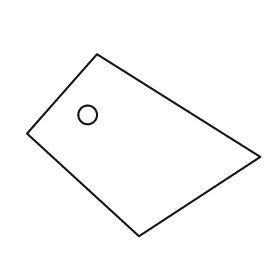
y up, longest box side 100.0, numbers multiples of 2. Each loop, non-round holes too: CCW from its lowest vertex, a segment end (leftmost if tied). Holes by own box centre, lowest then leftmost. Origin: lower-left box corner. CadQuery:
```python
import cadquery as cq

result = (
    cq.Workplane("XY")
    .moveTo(48.0, 0.0)
    .lineTo(100.0, 34.0)
    .lineTo(30.0, 78.0)
    .lineTo(0.0, 44.0)
    .close()
    .moveTo(26.0, 52.0)
    .circle(4.0)
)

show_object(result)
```